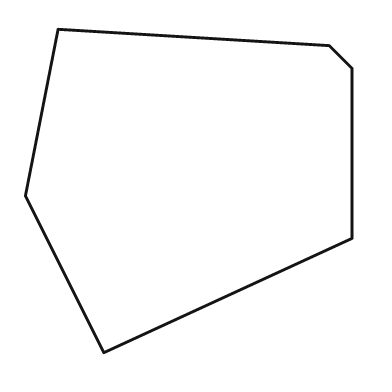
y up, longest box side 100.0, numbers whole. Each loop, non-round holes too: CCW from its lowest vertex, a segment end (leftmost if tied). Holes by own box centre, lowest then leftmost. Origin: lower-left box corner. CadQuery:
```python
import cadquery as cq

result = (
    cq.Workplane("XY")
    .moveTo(24.0, 0.0)
    .lineTo(100.0, 35.0)
    .lineTo(100.0, 87.0)
    .lineTo(93.0, 94.0)
    .lineTo(10.0, 99.0)
    .lineTo(0.0, 48.0)
    .close()
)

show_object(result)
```